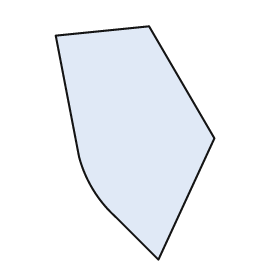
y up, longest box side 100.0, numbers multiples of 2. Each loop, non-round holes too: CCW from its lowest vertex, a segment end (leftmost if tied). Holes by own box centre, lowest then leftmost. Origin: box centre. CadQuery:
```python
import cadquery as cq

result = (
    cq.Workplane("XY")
    .moveTo(10.0, -50.0)
    .lineTo(34.0, 2.0)
    .lineTo(6.0, 50.0)
    .lineTo(-34.0, 46.0)
    .lineTo(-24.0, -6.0)
    .threePointArc((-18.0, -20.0), (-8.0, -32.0))
    .close()
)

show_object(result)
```